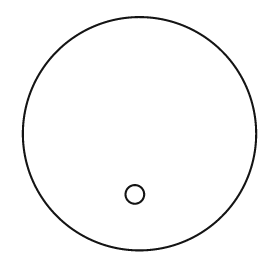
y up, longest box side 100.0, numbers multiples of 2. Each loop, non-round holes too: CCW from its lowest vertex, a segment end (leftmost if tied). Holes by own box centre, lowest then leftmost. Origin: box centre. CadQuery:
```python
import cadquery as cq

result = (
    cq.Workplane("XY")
    .moveTo(0.0, 0.0)
    .circle(50.0)
    .moveTo(-2.0, -26.0)
    .circle(4.0)
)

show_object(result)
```